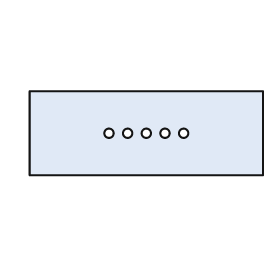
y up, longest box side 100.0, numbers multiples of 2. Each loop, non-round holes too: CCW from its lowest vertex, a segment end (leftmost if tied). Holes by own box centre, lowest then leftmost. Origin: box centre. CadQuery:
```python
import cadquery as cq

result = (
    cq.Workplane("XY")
    .moveTo(-50.0, -18.0)
    .lineTo(50.0, -18.0)
    .lineTo(50.0, 18.0)
    .lineTo(-50.0, 18.0)
    .close()
    .moveTo(-16.0, 0.0)
    .circle(2.0)
    .moveTo(-8.0, 0.0)
    .circle(2.0)
    .moveTo(0.0, 0.0)
    .circle(2.0)
    .moveTo(8.0, 0.0)
    .circle(2.0)
    .moveTo(16.0, 0.0)
    .circle(2.0)
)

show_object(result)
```